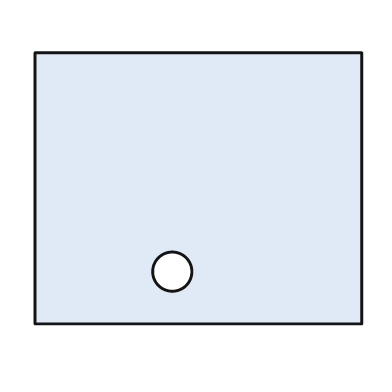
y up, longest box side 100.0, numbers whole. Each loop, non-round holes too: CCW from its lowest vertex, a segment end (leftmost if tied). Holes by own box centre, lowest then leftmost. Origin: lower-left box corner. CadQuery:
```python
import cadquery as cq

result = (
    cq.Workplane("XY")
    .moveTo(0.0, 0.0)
    .lineTo(100.0, 0.0)
    .lineTo(100.0, 83.0)
    .lineTo(0.0, 83.0)
    .close()
    .moveTo(42.0, 16.0)
    .circle(6.0)
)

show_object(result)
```